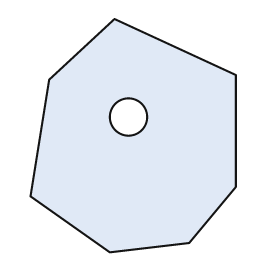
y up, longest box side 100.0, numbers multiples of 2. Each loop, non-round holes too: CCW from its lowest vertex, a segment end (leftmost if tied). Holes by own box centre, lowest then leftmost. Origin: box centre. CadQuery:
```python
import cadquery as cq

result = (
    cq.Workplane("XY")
    .moveTo(-10.0, -50.0)
    .lineTo(24.0, -46.0)
    .lineTo(44.0, -22.0)
    .lineTo(44.0, 26.0)
    .lineTo(-8.0, 50.0)
    .lineTo(-36.0, 24.0)
    .lineTo(-44.0, -26.0)
    .close()
    .moveTo(-2.0, 8.0)
    .circle(8.0)
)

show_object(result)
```